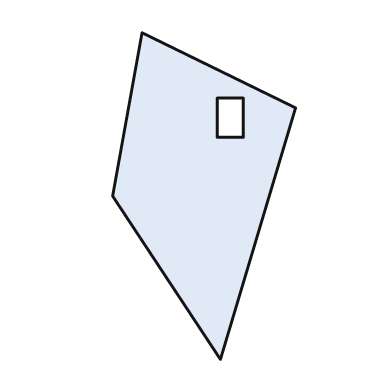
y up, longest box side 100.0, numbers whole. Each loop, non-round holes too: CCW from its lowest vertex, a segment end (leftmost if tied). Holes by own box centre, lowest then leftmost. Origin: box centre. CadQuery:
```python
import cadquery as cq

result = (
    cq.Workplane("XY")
    .moveTo(5.0, -50.0)
    .lineTo(28.0, 27.0)
    .lineTo(-19.0, 50.0)
    .lineTo(-28.0, 0.0)
    .close()
    .moveTo(4.0, 18.0)
    .lineTo(12.0, 18.0)
    .lineTo(12.0, 30.0)
    .lineTo(4.0, 30.0)
    .close()
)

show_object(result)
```